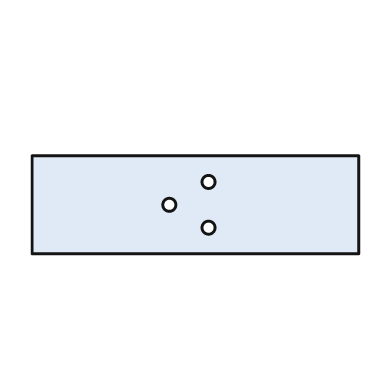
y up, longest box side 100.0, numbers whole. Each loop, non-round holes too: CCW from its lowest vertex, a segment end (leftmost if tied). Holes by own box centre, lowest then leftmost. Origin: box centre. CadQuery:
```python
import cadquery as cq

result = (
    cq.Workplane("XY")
    .moveTo(-50.0, -15.0)
    .lineTo(50.0, -15.0)
    .lineTo(50.0, 15.0)
    .lineTo(-50.0, 15.0)
    .close()
    .moveTo(4.0, -7.0)
    .circle(2.0)
    .moveTo(-8.0, 0.0)
    .circle(2.0)
    .moveTo(4.0, 7.0)
    .circle(2.0)
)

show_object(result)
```